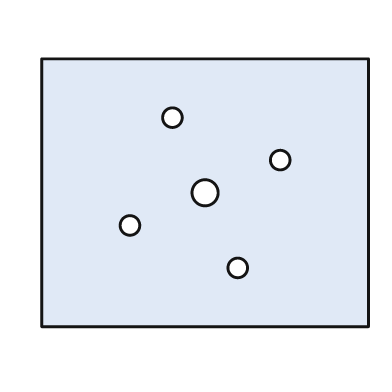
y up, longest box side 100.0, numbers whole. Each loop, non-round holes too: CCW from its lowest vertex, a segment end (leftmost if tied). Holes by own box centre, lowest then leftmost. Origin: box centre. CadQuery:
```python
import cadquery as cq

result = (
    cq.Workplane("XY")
    .moveTo(-50.0, -41.0)
    .lineTo(50.0, -41.0)
    .lineTo(50.0, 41.0)
    .lineTo(-50.0, 41.0)
    .close()
    .moveTo(10.0, -23.0)
    .circle(3.0)
    .moveTo(-23.0, -10.0)
    .circle(3.0)
    .moveTo(0.0, 0.0)
    .circle(4.0)
    .moveTo(23.0, 10.0)
    .circle(3.0)
    .moveTo(-10.0, 23.0)
    .circle(3.0)
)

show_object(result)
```